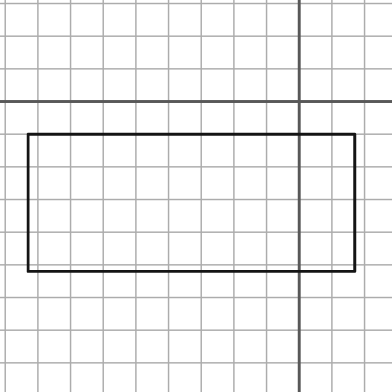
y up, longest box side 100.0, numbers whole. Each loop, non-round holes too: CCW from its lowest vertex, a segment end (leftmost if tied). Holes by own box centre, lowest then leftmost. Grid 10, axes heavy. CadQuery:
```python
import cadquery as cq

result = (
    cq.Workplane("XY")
    .moveTo(-83.0, -52.0)
    .lineTo(17.0, -52.0)
    .lineTo(17.0, -10.0)
    .lineTo(-83.0, -10.0)
    .close()
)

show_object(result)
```